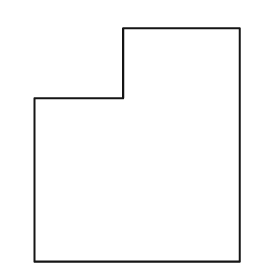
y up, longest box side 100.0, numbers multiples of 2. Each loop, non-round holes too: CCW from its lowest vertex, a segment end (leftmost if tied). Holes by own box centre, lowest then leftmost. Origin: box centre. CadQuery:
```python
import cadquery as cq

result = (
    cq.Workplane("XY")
    .moveTo(-44.0, -50.0)
    .lineTo(44.0, -50.0)
    .lineTo(44.0, 50.0)
    .lineTo(-6.0, 50.0)
    .lineTo(-6.0, 20.0)
    .lineTo(-44.0, 20.0)
    .close()
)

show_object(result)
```